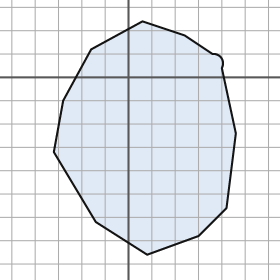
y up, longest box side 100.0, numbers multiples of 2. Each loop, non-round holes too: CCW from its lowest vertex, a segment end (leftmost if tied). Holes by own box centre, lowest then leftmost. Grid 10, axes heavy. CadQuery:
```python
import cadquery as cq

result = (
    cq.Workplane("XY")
    .moveTo(8.0, -76.0)
    .lineTo(30.0, -68.0)
    .lineTo(42.0, -56.0)
    .lineTo(46.0, -24.0)
    .lineTo(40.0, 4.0)
    .threePointArc((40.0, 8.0), (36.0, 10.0))
    .lineTo(24.0, 18.0)
    .lineTo(6.0, 24.0)
    .lineTo(-16.0, 12.0)
    .lineTo(-28.0, -10.0)
    .lineTo(-32.0, -32.0)
    .lineTo(-14.0, -62.0)
    .close()
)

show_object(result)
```